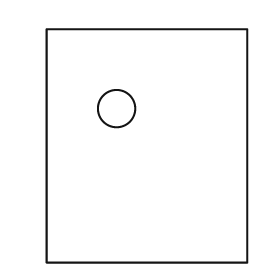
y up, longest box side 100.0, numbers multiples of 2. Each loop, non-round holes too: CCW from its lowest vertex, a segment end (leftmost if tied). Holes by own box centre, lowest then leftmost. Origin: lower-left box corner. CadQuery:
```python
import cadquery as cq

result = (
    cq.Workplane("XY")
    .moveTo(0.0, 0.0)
    .lineTo(86.0, 0.0)
    .lineTo(86.0, 100.0)
    .lineTo(0.0, 100.0)
    .close()
    .moveTo(30.0, 66.0)
    .circle(8.0)
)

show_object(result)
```